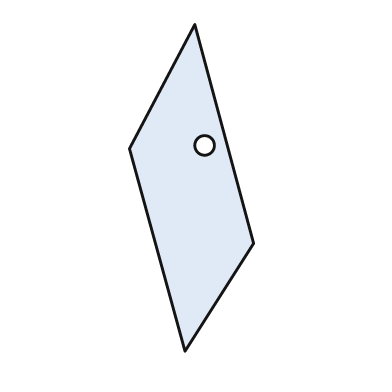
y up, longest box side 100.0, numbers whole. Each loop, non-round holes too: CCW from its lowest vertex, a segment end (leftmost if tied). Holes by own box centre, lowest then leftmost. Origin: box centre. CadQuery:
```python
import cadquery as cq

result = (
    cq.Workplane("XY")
    .moveTo(-2.0, -50.0)
    .lineTo(19.0, -17.0)
    .lineTo(1.0, 50.0)
    .lineTo(-19.0, 12.0)
    .close()
    .moveTo(4.0, 13.0)
    .circle(3.0)
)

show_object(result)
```